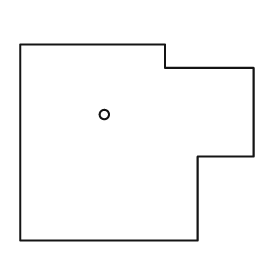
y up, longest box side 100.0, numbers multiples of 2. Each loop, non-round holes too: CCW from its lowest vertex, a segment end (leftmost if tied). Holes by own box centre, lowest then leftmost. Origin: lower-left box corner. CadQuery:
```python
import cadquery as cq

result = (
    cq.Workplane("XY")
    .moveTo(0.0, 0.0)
    .lineTo(76.0, 0.0)
    .lineTo(76.0, 36.0)
    .lineTo(100.0, 36.0)
    .lineTo(100.0, 74.0)
    .lineTo(62.0, 74.0)
    .lineTo(62.0, 84.0)
    .lineTo(0.0, 84.0)
    .close()
    .moveTo(36.0, 54.0)
    .circle(2.0)
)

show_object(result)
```